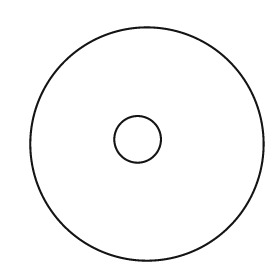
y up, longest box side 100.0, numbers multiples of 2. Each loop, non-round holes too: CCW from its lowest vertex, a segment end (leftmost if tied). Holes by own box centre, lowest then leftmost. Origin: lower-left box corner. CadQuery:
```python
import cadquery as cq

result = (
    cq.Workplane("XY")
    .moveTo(50.0, 50.0)
    .circle(50.0)
    .moveTo(46.0, 52.0)
    .circle(10.0)
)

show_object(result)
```